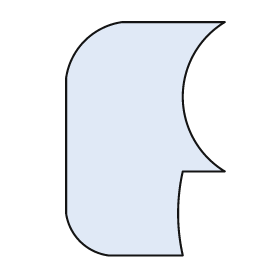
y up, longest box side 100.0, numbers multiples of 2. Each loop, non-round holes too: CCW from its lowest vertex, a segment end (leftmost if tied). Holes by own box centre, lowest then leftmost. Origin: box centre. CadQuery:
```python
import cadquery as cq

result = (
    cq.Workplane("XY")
    .moveTo(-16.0, -50.0)
    .lineTo(16.0, -50.0)
    .threePointArc((14.0, -32.0), (16.0, -14.0))
    .lineTo(34.0, -14.0)
    .threePointArc((16.0, 18.0), (34.0, 50.0))
    .lineTo(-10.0, 50.0)
    .threePointArc((-26.0, 42.0), (-34.0, 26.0))
    .lineTo(-34.0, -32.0)
    .threePointArc((-28.0, -44.0), (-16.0, -50.0))
    .close()
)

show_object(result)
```